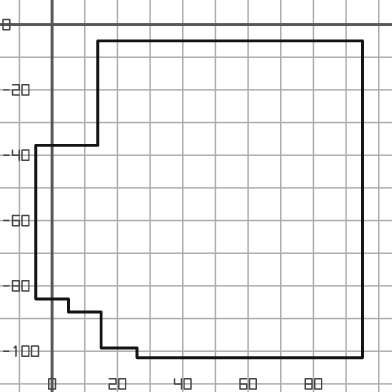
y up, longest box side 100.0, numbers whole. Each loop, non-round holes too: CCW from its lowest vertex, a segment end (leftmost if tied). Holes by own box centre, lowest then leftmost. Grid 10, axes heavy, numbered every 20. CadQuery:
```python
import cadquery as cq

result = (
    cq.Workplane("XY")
    .moveTo(26.0, -102.0)
    .lineTo(95.0, -102.0)
    .lineTo(95.0, -5.0)
    .lineTo(14.0, -5.0)
    .lineTo(14.0, -37.0)
    .lineTo(-5.0, -37.0)
    .lineTo(-5.0, -84.0)
    .lineTo(5.0, -84.0)
    .lineTo(5.0, -88.0)
    .lineTo(15.0, -88.0)
    .lineTo(15.0, -99.0)
    .lineTo(26.0, -99.0)
    .close()
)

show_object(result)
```